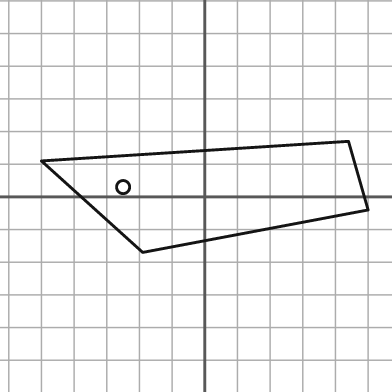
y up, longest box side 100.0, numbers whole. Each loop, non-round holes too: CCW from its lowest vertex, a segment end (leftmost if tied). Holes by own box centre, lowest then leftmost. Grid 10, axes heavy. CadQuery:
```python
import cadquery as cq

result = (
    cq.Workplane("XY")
    .moveTo(-19.0, -17.0)
    .lineTo(50.0, -4.0)
    .lineTo(44.0, 17.0)
    .lineTo(-50.0, 11.0)
    .close()
    .moveTo(-25.0, 3.0)
    .circle(2.0)
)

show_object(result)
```